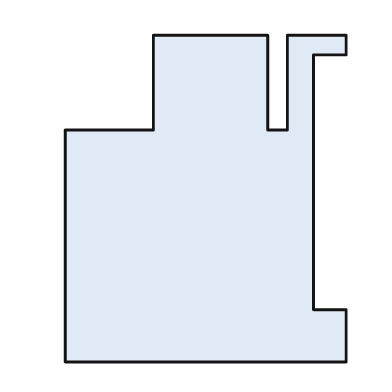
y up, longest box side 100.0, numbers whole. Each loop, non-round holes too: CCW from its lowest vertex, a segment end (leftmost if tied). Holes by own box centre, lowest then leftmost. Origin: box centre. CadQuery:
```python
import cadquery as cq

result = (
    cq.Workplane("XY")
    .moveTo(-43.0, -50.0)
    .lineTo(43.0, -50.0)
    .lineTo(43.0, -34.0)
    .lineTo(33.0, -34.0)
    .lineTo(33.0, 44.0)
    .lineTo(43.0, 44.0)
    .lineTo(43.0, 50.0)
    .lineTo(25.0, 50.0)
    .lineTo(25.0, 21.0)
    .lineTo(19.0, 21.0)
    .lineTo(19.0, 50.0)
    .lineTo(-16.0, 50.0)
    .lineTo(-16.0, 21.0)
    .lineTo(-43.0, 21.0)
    .close()
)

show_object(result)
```